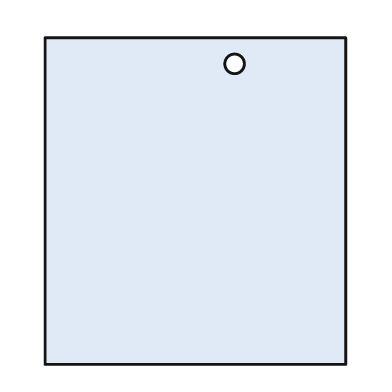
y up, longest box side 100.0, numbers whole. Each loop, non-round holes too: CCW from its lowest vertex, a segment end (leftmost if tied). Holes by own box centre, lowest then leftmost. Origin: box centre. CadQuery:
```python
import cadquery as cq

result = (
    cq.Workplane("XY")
    .moveTo(-46.0, -50.0)
    .lineTo(46.0, -50.0)
    .lineTo(46.0, 50.0)
    .lineTo(-46.0, 50.0)
    .close()
    .moveTo(12.0, 42.0)
    .circle(3.0)
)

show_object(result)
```